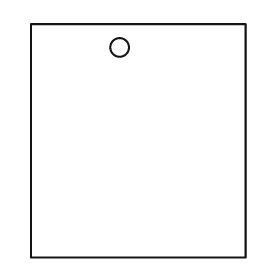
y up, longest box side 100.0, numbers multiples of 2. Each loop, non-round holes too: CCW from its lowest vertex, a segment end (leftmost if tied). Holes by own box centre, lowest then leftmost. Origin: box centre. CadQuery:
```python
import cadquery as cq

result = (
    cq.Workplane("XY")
    .moveTo(-46.0, -50.0)
    .lineTo(46.0, -50.0)
    .lineTo(46.0, 50.0)
    .lineTo(-46.0, 50.0)
    .close()
    .moveTo(-8.0, 40.0)
    .circle(4.0)
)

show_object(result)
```